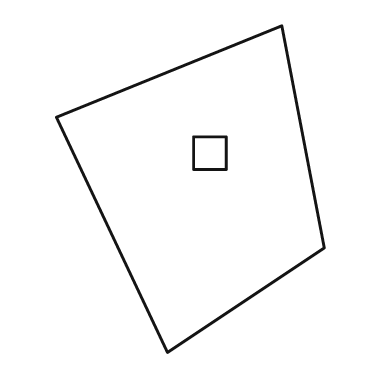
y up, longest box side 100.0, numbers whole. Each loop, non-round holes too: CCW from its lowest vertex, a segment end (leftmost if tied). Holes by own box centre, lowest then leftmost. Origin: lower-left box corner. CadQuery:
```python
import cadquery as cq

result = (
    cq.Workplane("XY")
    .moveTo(34.0, 0.0)
    .lineTo(82.0, 32.0)
    .lineTo(69.0, 100.0)
    .lineTo(0.0, 72.0)
    .close()
    .moveTo(42.0, 56.0)
    .lineTo(52.0, 56.0)
    .lineTo(52.0, 66.0)
    .lineTo(42.0, 66.0)
    .close()
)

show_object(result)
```